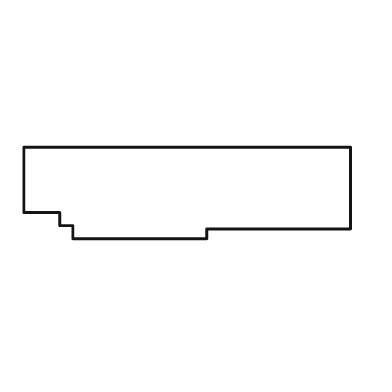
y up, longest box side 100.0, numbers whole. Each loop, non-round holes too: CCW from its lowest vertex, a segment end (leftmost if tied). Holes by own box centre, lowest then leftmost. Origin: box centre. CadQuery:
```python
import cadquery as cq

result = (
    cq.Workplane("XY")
    .moveTo(-35.0, -14.0)
    .lineTo(6.0, -14.0)
    .lineTo(6.0, -11.0)
    .lineTo(50.0, -11.0)
    .lineTo(50.0, 14.0)
    .lineTo(-50.0, 14.0)
    .lineTo(-50.0, -6.0)
    .lineTo(-39.0, -6.0)
    .lineTo(-39.0, -10.0)
    .lineTo(-35.0, -10.0)
    .close()
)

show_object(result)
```